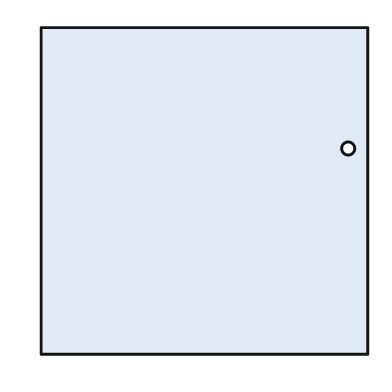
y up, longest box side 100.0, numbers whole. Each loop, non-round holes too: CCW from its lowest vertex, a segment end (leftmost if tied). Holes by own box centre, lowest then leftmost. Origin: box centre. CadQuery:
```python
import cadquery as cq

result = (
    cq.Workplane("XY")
    .moveTo(-50.0, -50.0)
    .lineTo(50.0, -50.0)
    .lineTo(50.0, 50.0)
    .lineTo(-50.0, 50.0)
    .close()
    .moveTo(44.0, 13.0)
    .circle(2.0)
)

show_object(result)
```